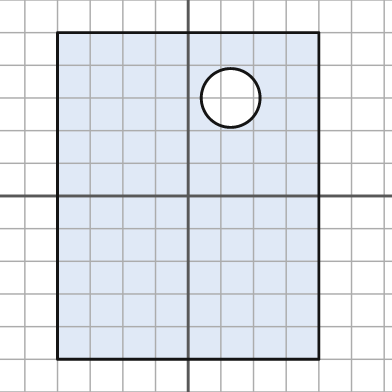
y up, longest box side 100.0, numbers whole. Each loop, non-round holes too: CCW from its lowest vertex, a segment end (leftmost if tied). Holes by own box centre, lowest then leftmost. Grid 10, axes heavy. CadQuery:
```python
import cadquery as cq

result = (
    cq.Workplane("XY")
    .moveTo(-40.0, -50.0)
    .lineTo(40.0, -50.0)
    .lineTo(40.0, 50.0)
    .lineTo(-40.0, 50.0)
    .close()
    .moveTo(13.0, 30.0)
    .circle(9.0)
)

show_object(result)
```